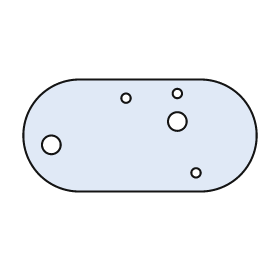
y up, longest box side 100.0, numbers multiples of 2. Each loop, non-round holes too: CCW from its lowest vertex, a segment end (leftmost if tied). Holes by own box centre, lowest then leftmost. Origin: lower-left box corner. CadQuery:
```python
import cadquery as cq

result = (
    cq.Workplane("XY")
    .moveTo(24.0, 0.0)
    .lineTo(76.0, 0.0)
    .threePointArc((100.0, 24.0), (76.0, 48.0))
    .lineTo(24.0, 48.0)
    .threePointArc((0.0, 24.0), (24.0, 0.0))
    .close()
    .moveTo(74.0, 8.0)
    .circle(2.0)
    .moveTo(12.0, 20.0)
    .circle(4.0)
    .moveTo(66.0, 30.0)
    .circle(4.0)
    .moveTo(44.0, 40.0)
    .circle(2.0)
    .moveTo(66.0, 42.0)
    .circle(2.0)
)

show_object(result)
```